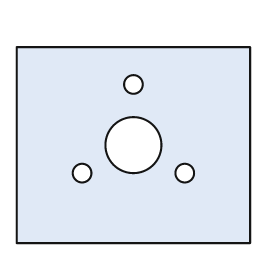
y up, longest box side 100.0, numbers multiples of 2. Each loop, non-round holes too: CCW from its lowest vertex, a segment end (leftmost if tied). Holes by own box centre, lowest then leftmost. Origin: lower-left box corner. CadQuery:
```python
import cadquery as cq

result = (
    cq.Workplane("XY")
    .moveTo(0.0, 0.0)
    .lineTo(100.0, 0.0)
    .lineTo(100.0, 84.0)
    .lineTo(0.0, 84.0)
    .close()
    .moveTo(28.0, 30.0)
    .circle(4.0)
    .moveTo(72.0, 30.0)
    .circle(4.0)
    .moveTo(50.0, 42.0)
    .circle(12.0)
    .moveTo(50.0, 68.0)
    .circle(4.0)
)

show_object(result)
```